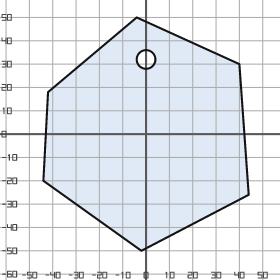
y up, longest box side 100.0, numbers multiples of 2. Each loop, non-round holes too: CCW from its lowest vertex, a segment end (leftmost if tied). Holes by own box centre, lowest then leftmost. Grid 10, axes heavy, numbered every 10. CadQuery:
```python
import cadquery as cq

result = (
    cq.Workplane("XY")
    .moveTo(-2.0, -50.0)
    .lineTo(44.0, -26.0)
    .lineTo(40.0, 30.0)
    .lineTo(-4.0, 50.0)
    .lineTo(-42.0, 18.0)
    .lineTo(-44.0, -20.0)
    .close()
    .moveTo(0.0, 32.0)
    .circle(4.0)
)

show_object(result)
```